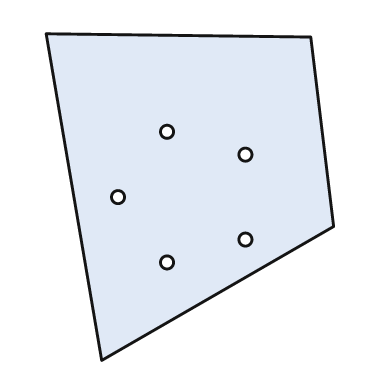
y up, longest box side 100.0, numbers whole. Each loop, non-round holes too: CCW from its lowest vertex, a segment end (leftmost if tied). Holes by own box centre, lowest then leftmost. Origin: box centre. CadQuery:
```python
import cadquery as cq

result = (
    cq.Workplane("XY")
    .moveTo(-27.0, -50.0)
    .lineTo(44.0, -9.0)
    .lineTo(37.0, 49.0)
    .lineTo(-44.0, 50.0)
    .close()
    .moveTo(-7.0, -20.0)
    .circle(2.0)
    .moveTo(17.0, -13.0)
    .circle(2.0)
    .moveTo(-22.0, 0.0)
    .circle(2.0)
    .moveTo(17.0, 13.0)
    .circle(2.0)
    .moveTo(-7.0, 20.0)
    .circle(2.0)
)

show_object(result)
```